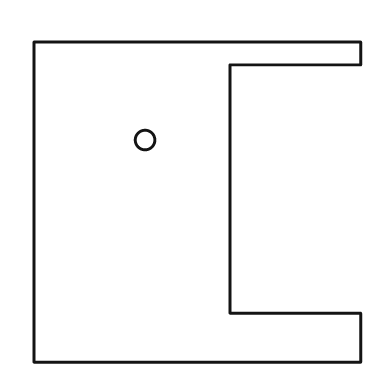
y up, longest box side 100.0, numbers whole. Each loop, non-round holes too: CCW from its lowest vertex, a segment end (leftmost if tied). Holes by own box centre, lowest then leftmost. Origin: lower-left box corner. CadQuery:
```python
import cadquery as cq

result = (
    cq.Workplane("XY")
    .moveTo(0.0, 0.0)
    .lineTo(100.0, 0.0)
    .lineTo(100.0, 15.0)
    .lineTo(60.0, 15.0)
    .lineTo(60.0, 91.0)
    .lineTo(100.0, 91.0)
    .lineTo(100.0, 98.0)
    .lineTo(0.0, 98.0)
    .close()
    .moveTo(34.0, 68.0)
    .circle(3.0)
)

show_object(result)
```